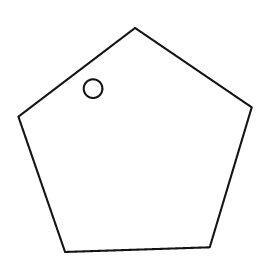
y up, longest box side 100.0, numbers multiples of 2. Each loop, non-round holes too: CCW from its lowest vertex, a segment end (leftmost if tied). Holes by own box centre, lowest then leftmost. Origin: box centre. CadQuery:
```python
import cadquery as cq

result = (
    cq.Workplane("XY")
    .moveTo(-30.0, -48.0)
    .lineTo(32.0, -46.0)
    .lineTo(50.0, 14.0)
    .lineTo(0.0, 48.0)
    .lineTo(-50.0, 10.0)
    .close()
    .moveTo(-18.0, 22.0)
    .circle(4.0)
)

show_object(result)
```